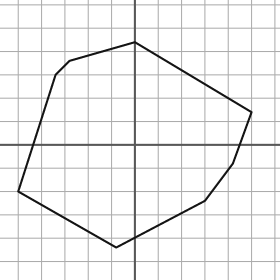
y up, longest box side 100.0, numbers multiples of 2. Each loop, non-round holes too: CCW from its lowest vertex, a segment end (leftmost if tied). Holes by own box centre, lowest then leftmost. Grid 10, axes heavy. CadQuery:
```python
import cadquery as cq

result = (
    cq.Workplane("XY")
    .moveTo(-8.0, -44.0)
    .lineTo(30.0, -24.0)
    .lineTo(42.0, -8.0)
    .lineTo(50.0, 14.0)
    .lineTo(0.0, 44.0)
    .lineTo(-28.0, 36.0)
    .lineTo(-34.0, 30.0)
    .lineTo(-50.0, -20.0)
    .close()
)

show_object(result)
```